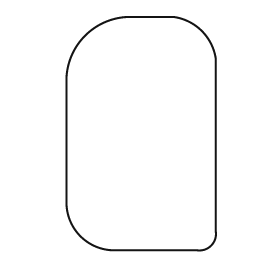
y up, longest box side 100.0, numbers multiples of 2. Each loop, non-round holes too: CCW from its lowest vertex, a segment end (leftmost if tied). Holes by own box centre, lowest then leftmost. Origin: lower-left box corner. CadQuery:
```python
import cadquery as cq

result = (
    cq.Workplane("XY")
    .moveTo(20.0, 0.0)
    .lineTo(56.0, 0.0)
    .threePointArc((62.0, 2.0), (64.0, 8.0))
    .lineTo(64.0, 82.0)
    .threePointArc((58.0, 94.0), (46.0, 100.0))
    .lineTo(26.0, 100.0)
    .threePointArc((8.0, 92.0), (0.0, 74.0))
    .lineTo(0.0, 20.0)
    .threePointArc((6.0, 6.0), (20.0, 0.0))
    .close()
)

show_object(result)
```